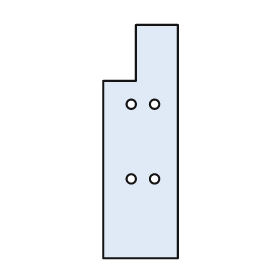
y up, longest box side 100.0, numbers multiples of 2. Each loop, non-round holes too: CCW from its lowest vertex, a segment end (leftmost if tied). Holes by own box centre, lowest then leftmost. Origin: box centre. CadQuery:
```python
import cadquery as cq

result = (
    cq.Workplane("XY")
    .moveTo(-16.0, -50.0)
    .lineTo(16.0, -50.0)
    .lineTo(16.0, 50.0)
    .lineTo(-2.0, 50.0)
    .lineTo(-2.0, 26.0)
    .lineTo(-16.0, 26.0)
    .close()
    .moveTo(-4.0, -16.0)
    .circle(2.0)
    .moveTo(6.0, -16.0)
    .circle(2.0)
    .moveTo(-4.0, 16.0)
    .circle(2.0)
    .moveTo(6.0, 16.0)
    .circle(2.0)
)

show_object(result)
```